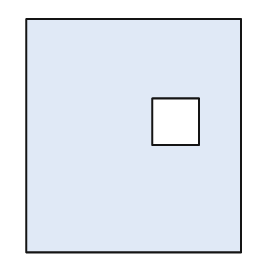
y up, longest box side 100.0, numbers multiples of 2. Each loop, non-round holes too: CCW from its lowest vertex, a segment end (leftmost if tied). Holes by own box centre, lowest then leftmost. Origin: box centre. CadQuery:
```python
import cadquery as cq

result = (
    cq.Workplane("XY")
    .moveTo(-46.0, -50.0)
    .lineTo(46.0, -50.0)
    .lineTo(46.0, 50.0)
    .lineTo(-46.0, 50.0)
    .close()
    .moveTo(8.0, -4.0)
    .lineTo(28.0, -4.0)
    .lineTo(28.0, 16.0)
    .lineTo(8.0, 16.0)
    .close()
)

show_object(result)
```